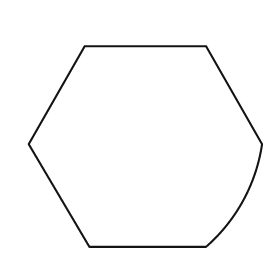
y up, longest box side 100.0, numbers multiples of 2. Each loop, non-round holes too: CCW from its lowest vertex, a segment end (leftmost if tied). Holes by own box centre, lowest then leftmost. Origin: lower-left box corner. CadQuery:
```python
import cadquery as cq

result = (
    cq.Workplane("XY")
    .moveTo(26.0, 0.0)
    .lineTo(76.0, 0.0)
    .threePointArc((92.0, 20.0), (100.0, 44.0))
    .lineTo(76.0, 86.0)
    .lineTo(24.0, 86.0)
    .lineTo(0.0, 44.0)
    .close()
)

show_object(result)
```